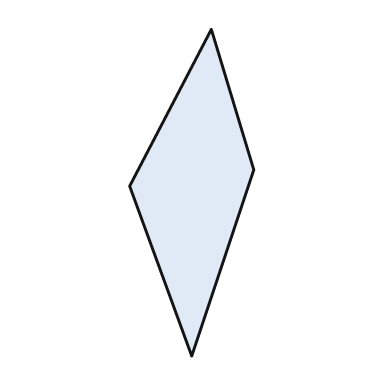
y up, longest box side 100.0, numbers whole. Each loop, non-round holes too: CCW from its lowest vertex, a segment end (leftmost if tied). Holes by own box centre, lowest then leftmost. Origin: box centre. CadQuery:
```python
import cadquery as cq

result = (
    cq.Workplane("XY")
    .moveTo(0.0, -50.0)
    .lineTo(19.0, 7.0)
    .lineTo(6.0, 50.0)
    .lineTo(-19.0, 2.0)
    .close()
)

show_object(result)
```